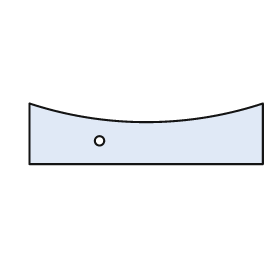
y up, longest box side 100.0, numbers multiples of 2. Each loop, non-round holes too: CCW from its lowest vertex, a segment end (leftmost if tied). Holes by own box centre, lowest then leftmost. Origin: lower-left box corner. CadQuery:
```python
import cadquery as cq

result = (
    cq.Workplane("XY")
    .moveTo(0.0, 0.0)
    .lineTo(100.0, 0.0)
    .lineTo(100.0, 26.0)
    .threePointArc((50.0, 18.0), (0.0, 26.0))
    .close()
    .moveTo(30.0, 10.0)
    .circle(2.0)
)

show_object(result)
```